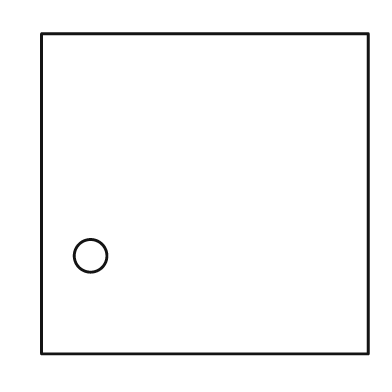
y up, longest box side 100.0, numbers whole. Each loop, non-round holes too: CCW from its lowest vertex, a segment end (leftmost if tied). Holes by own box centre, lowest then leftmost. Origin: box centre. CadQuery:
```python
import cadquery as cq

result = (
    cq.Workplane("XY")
    .moveTo(-50.0, -49.0)
    .lineTo(50.0, -49.0)
    .lineTo(50.0, 49.0)
    .lineTo(-50.0, 49.0)
    .close()
    .moveTo(-35.0, -19.0)
    .circle(5.0)
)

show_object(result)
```